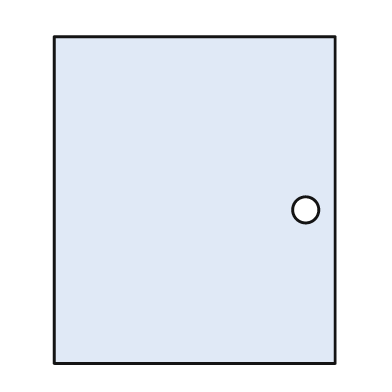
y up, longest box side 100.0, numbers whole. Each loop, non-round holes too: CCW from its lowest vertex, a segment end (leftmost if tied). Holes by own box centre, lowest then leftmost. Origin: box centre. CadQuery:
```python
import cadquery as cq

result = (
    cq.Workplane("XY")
    .moveTo(-43.0, -50.0)
    .lineTo(43.0, -50.0)
    .lineTo(43.0, 50.0)
    .lineTo(-43.0, 50.0)
    .close()
    .moveTo(34.0, -3.0)
    .circle(4.0)
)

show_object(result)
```